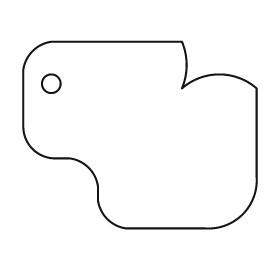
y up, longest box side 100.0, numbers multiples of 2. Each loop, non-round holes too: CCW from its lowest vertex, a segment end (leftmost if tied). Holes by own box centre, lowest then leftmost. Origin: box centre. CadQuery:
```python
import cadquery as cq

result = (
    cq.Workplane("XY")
    .moveTo(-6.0, -40.0)
    .lineTo(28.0, -40.0)
    .threePointArc((44.0, -34.0), (50.0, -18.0))
    .lineTo(50.0, 20.0)
    .threePointArc((34.0, 26.0), (18.0, 20.0))
    .threePointArc((20.0, 30.0), (18.0, 40.0))
    .lineTo(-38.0, 40.0)
    .threePointArc((-46.0, 36.0), (-50.0, 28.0))
    .lineTo(-50.0, 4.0)
    .threePointArc((-46.0, -6.0), (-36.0, -10.0))
    .lineTo(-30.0, -10.0)
    .threePointArc((-22.0, -14.0), (-18.0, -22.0))
    .lineTo(-18.0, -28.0)
    .threePointArc((-14.0, -36.0), (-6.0, -40.0))
    .close()
    .moveTo(-38.0, 22.0)
    .circle(4.0)
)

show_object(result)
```